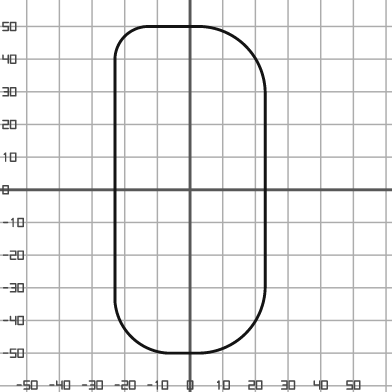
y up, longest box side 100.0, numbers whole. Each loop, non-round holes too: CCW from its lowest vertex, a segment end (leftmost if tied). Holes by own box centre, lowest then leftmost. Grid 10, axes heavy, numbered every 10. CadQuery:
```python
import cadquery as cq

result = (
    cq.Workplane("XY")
    .moveTo(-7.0, -50.0)
    .lineTo(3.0, -50.0)
    .threePointArc((17.0, -44.0), (23.0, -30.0))
    .lineTo(23.0, 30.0)
    .threePointArc((17.0, 44.0), (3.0, 50.0))
    .lineTo(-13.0, 50.0)
    .threePointArc((-20.0, 47.0), (-23.0, 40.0))
    .lineTo(-23.0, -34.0)
    .threePointArc((-18.0, -45.0), (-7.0, -50.0))
    .close()
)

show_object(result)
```